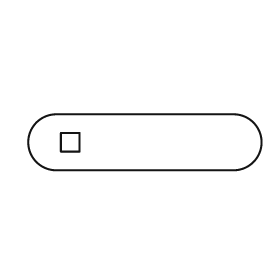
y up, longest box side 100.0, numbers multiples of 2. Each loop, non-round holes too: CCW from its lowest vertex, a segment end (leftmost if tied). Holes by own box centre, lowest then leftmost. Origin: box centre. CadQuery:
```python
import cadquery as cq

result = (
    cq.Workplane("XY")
    .moveTo(-38.0, -12.0)
    .lineTo(38.0, -12.0)
    .threePointArc((50.0, 0.0), (38.0, 12.0))
    .lineTo(-38.0, 12.0)
    .threePointArc((-50.0, 0.0), (-38.0, -12.0))
    .close()
    .moveTo(-36.0, -4.0)
    .lineTo(-28.0, -4.0)
    .lineTo(-28.0, 4.0)
    .lineTo(-36.0, 4.0)
    .close()
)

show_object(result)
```